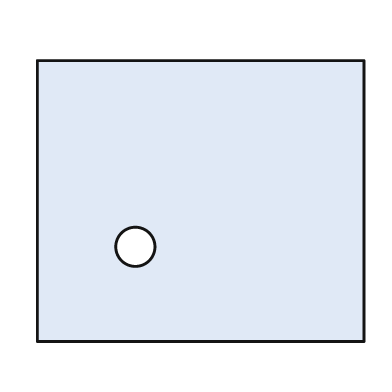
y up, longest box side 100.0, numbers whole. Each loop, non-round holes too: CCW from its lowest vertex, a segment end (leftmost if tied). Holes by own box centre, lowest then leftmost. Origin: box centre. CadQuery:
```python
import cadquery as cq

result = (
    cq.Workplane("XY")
    .moveTo(-50.0, -43.0)
    .lineTo(50.0, -43.0)
    .lineTo(50.0, 43.0)
    .lineTo(-50.0, 43.0)
    .close()
    .moveTo(-20.0, -14.0)
    .circle(6.0)
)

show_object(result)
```